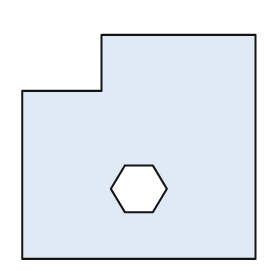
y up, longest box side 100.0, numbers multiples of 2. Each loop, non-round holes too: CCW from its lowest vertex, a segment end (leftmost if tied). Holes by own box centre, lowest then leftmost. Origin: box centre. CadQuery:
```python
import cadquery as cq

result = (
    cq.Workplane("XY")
    .moveTo(-50.0, -48.0)
    .lineTo(50.0, -48.0)
    .lineTo(50.0, 48.0)
    .lineTo(-16.0, 48.0)
    .lineTo(-16.0, 24.0)
    .lineTo(-50.0, 24.0)
    .close()
    .moveTo(-6.0, -28.0)
    .lineTo(6.0, -28.0)
    .lineTo(12.0, -18.0)
    .lineTo(6.0, -8.0)
    .lineTo(-6.0, -8.0)
    .lineTo(-12.0, -18.0)
    .close()
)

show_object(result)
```